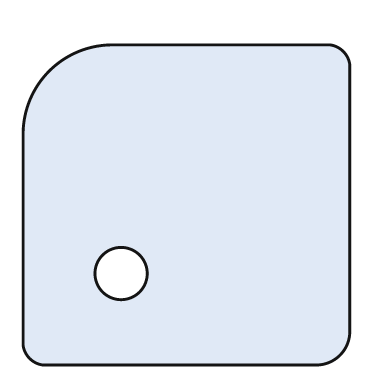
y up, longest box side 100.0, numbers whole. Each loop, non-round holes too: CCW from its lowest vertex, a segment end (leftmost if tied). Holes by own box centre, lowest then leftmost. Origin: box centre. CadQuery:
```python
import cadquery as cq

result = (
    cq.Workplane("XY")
    .moveTo(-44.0, -49.0)
    .lineTo(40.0, -49.0)
    .threePointArc((47.0, -46.0), (50.0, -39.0))
    .lineTo(50.0, 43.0)
    .threePointArc((48.0, 47.0), (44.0, 49.0))
    .lineTo(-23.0, 49.0)
    .threePointArc((-42.0, 41.0), (-50.0, 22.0))
    .lineTo(-50.0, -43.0)
    .threePointArc((-48.0, -47.0), (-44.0, -49.0))
    .close()
    .moveTo(-20.0, -21.0)
    .circle(8.0)
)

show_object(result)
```